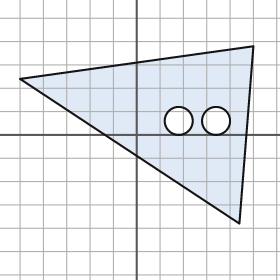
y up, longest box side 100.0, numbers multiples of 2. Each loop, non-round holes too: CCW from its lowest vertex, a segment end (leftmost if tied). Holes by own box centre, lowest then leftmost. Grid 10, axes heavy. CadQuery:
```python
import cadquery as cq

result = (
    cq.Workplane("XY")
    .moveTo(44.0, -38.0)
    .lineTo(50.0, 38.0)
    .lineTo(-50.0, 24.0)
    .close()
    .moveTo(18.0, 6.0)
    .circle(6.0)
    .moveTo(34.0, 6.0)
    .circle(6.0)
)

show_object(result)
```